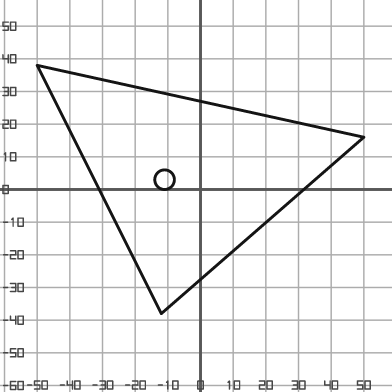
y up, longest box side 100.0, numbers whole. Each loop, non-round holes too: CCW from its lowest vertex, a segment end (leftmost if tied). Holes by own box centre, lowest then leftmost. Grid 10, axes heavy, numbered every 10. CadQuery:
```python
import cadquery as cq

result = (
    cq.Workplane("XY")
    .moveTo(-12.0, -38.0)
    .lineTo(50.0, 16.0)
    .lineTo(-50.0, 38.0)
    .close()
    .moveTo(-11.0, 3.0)
    .circle(3.0)
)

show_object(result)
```